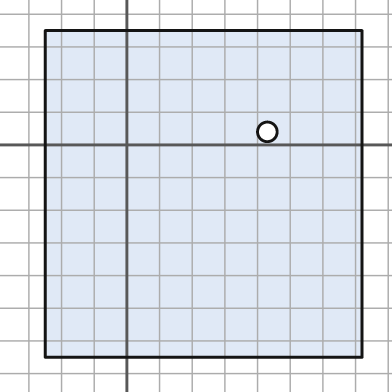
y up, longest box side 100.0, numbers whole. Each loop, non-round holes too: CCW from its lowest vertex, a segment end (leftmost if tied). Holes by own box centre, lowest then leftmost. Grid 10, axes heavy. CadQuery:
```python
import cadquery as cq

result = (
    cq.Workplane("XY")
    .moveTo(-25.0, -65.0)
    .lineTo(72.0, -65.0)
    .lineTo(72.0, 35.0)
    .lineTo(-25.0, 35.0)
    .close()
    .moveTo(43.0, 4.0)
    .circle(3.0)
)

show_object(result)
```